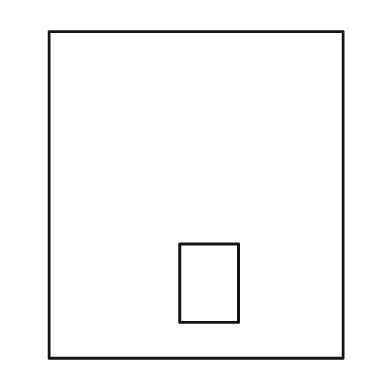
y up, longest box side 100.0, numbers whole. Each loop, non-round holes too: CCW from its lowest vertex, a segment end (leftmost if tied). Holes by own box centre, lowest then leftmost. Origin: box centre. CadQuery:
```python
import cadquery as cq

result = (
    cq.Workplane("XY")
    .moveTo(-45.0, -50.0)
    .lineTo(45.0, -50.0)
    .lineTo(45.0, 50.0)
    .lineTo(-45.0, 50.0)
    .close()
    .moveTo(-5.0, -39.0)
    .lineTo(13.0, -39.0)
    .lineTo(13.0, -15.0)
    .lineTo(-5.0, -15.0)
    .close()
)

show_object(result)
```